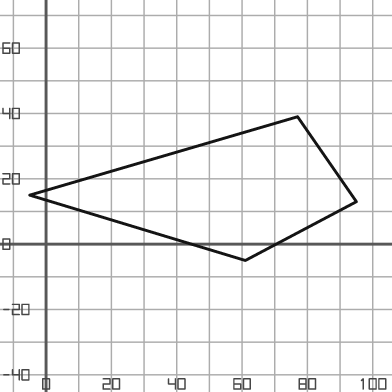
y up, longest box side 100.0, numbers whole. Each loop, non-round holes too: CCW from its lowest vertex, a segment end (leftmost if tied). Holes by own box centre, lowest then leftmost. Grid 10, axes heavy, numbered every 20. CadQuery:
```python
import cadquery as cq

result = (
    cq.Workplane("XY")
    .moveTo(61.0, -5.0)
    .lineTo(95.0, 13.0)
    .lineTo(77.0, 39.0)
    .lineTo(-5.0, 15.0)
    .close()
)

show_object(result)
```